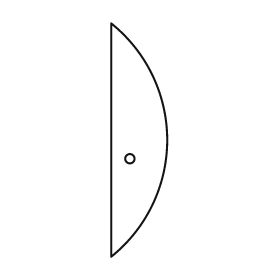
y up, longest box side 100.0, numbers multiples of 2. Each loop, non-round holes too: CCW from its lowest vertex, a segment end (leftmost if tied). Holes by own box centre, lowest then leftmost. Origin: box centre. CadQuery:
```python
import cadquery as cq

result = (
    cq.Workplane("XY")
    .moveTo(-12.0, -50.0)
    .threePointArc((12.0, 0.0), (-12.0, 50.0))
    .close()
    .moveTo(-4.0, -8.0)
    .circle(2.0)
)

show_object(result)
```